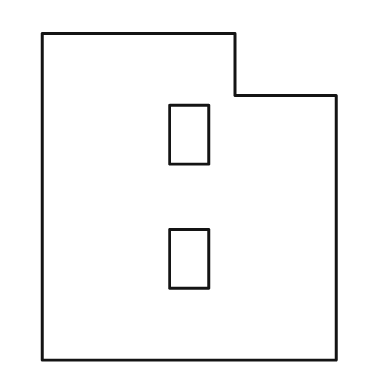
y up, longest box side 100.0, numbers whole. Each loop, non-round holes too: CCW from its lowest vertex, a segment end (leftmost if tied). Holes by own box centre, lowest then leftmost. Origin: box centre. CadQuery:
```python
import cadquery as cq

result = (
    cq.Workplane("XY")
    .moveTo(-45.0, -50.0)
    .lineTo(45.0, -50.0)
    .lineTo(45.0, 31.0)
    .lineTo(14.0, 31.0)
    .lineTo(14.0, 50.0)
    .lineTo(-45.0, 50.0)
    .close()
    .moveTo(-6.0, -28.0)
    .lineTo(6.0, -28.0)
    .lineTo(6.0, -10.0)
    .lineTo(-6.0, -10.0)
    .close()
    .moveTo(-6.0, 10.0)
    .lineTo(6.0, 10.0)
    .lineTo(6.0, 28.0)
    .lineTo(-6.0, 28.0)
    .close()
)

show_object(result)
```